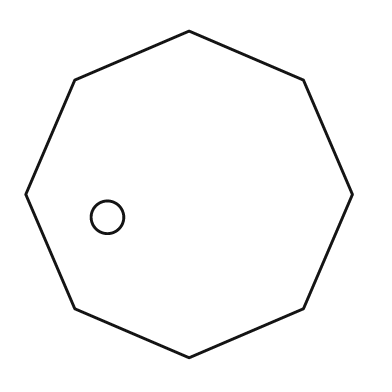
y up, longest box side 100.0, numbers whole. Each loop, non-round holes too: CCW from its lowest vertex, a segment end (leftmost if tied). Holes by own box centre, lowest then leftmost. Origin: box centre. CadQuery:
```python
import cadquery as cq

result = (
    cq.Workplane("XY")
    .moveTo(0.0, -50.0)
    .lineTo(35.0, -35.0)
    .lineTo(50.0, 0.0)
    .lineTo(35.0, 35.0)
    .lineTo(0.0, 50.0)
    .lineTo(-35.0, 35.0)
    .lineTo(-50.0, 0.0)
    .lineTo(-35.0, -35.0)
    .close()
    .moveTo(-25.0, -7.0)
    .circle(5.0)
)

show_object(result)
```